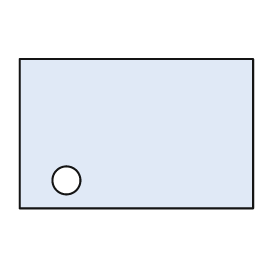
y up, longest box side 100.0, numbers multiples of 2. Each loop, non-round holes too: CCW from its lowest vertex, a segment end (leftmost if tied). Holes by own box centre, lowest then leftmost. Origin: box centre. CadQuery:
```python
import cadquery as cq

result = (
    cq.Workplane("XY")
    .moveTo(-50.0, -32.0)
    .lineTo(50.0, -32.0)
    .lineTo(50.0, 32.0)
    .lineTo(-50.0, 32.0)
    .close()
    .moveTo(-30.0, -20.0)
    .circle(6.0)
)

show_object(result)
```